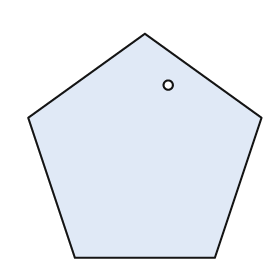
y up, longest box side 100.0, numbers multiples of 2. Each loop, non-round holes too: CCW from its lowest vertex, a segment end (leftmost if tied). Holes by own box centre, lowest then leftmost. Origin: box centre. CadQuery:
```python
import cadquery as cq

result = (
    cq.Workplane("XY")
    .moveTo(-30.0, -48.0)
    .lineTo(30.0, -48.0)
    .lineTo(50.0, 12.0)
    .lineTo(0.0, 48.0)
    .lineTo(-50.0, 12.0)
    .close()
    .moveTo(10.0, 26.0)
    .circle(2.0)
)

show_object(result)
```